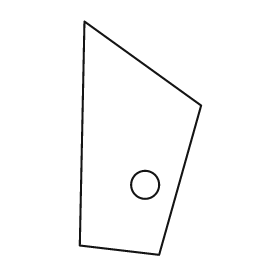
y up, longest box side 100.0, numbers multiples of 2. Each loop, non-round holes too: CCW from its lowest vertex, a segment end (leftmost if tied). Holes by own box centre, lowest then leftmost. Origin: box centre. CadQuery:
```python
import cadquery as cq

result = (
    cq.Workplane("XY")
    .moveTo(8.0, -50.0)
    .lineTo(26.0, 14.0)
    .lineTo(-24.0, 50.0)
    .lineTo(-26.0, -46.0)
    .close()
    .moveTo(2.0, -20.0)
    .circle(6.0)
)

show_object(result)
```